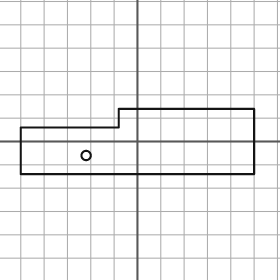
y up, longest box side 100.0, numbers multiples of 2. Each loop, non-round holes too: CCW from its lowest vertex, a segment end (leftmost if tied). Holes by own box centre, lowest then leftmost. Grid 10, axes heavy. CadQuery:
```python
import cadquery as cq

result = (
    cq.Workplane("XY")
    .moveTo(-50.0, -14.0)
    .lineTo(50.0, -14.0)
    .lineTo(50.0, 14.0)
    .lineTo(-8.0, 14.0)
    .lineTo(-8.0, 6.0)
    .lineTo(-50.0, 6.0)
    .close()
    .moveTo(-22.0, -6.0)
    .circle(2.0)
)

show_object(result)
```